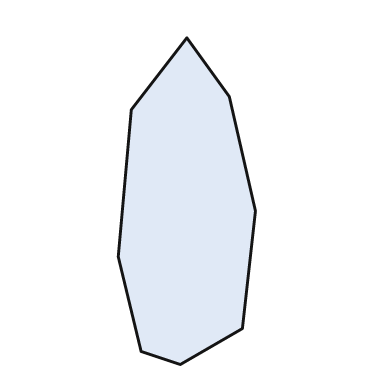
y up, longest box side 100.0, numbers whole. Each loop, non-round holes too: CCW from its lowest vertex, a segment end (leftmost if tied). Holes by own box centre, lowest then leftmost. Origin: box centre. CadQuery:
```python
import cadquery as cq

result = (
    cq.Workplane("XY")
    .moveTo(-2.0, -50.0)
    .lineTo(17.0, -39.0)
    .lineTo(21.0, -3.0)
    .lineTo(13.0, 32.0)
    .lineTo(0.0, 50.0)
    .lineTo(-17.0, 28.0)
    .lineTo(-21.0, -17.0)
    .lineTo(-14.0, -46.0)
    .close()
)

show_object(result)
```